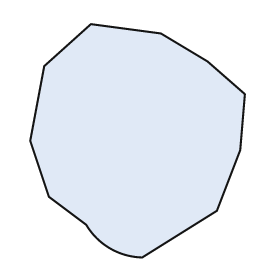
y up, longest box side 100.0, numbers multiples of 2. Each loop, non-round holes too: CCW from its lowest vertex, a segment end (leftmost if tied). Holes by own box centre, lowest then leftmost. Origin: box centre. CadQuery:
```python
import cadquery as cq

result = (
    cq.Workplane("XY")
    .moveTo(2.0, -50.0)
    .lineTo(34.0, -30.0)
    .lineTo(44.0, -4.0)
    .lineTo(46.0, 20.0)
    .lineTo(30.0, 34.0)
    .lineTo(10.0, 46.0)
    .lineTo(-20.0, 50.0)
    .lineTo(-40.0, 32.0)
    .lineTo(-46.0, 0.0)
    .lineTo(-38.0, -24.0)
    .lineTo(-22.0, -36.0)
    .threePointArc((-12.0, -46.0), (2.0, -50.0))
    .close()
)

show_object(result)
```